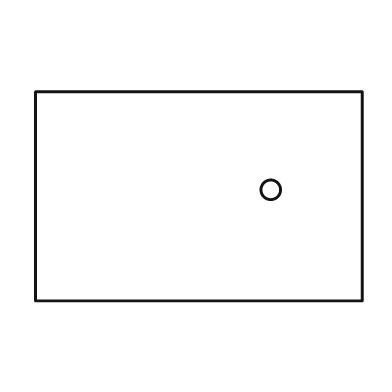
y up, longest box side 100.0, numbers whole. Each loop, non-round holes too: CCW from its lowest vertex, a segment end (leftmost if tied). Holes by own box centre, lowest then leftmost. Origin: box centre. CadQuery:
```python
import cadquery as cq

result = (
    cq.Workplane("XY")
    .moveTo(-50.0, -32.0)
    .lineTo(50.0, -32.0)
    .lineTo(50.0, 32.0)
    .lineTo(-50.0, 32.0)
    .close()
    .moveTo(22.0, 2.0)
    .circle(3.0)
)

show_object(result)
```